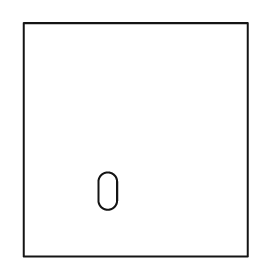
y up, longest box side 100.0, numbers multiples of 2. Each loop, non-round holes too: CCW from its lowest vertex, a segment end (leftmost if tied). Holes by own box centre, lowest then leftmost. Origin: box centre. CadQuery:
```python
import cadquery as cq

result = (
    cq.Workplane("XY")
    .moveTo(-48.0, -50.0)
    .lineTo(48.0, -50.0)
    .lineTo(48.0, 50.0)
    .lineTo(-48.0, 50.0)
    .close()
    .moveTo(-16.0, -26.0)
    .threePointArc((-12.0, -30.0), (-8.0, -26.0))
    .lineTo(-8.0, -18.0)
    .threePointArc((-12.0, -14.0), (-16.0, -18.0))
    .close()
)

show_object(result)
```